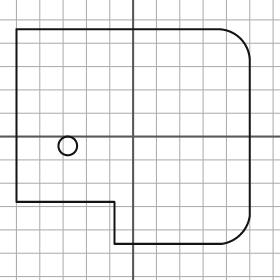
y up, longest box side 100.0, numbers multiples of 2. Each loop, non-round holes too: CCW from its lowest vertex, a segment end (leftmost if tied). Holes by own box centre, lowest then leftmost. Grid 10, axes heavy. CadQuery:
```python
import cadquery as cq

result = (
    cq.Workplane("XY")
    .moveTo(-8.0, -46.0)
    .lineTo(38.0, -46.0)
    .threePointArc((46.0, -42.0), (50.0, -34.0))
    .lineTo(50.0, 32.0)
    .threePointArc((46.0, 42.0), (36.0, 46.0))
    .lineTo(-50.0, 46.0)
    .lineTo(-50.0, -28.0)
    .lineTo(-8.0, -28.0)
    .close()
    .moveTo(-28.0, -4.0)
    .circle(4.0)
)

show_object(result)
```